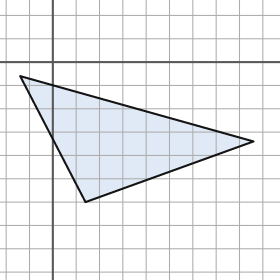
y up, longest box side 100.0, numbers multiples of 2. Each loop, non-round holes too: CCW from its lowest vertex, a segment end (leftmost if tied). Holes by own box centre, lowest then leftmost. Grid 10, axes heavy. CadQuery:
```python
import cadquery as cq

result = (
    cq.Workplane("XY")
    .moveTo(14.0, -60.0)
    .lineTo(86.0, -34.0)
    .lineTo(-14.0, -6.0)
    .close()
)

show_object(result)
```